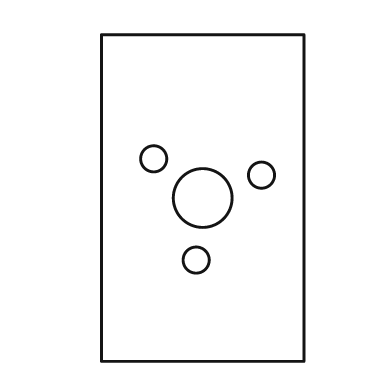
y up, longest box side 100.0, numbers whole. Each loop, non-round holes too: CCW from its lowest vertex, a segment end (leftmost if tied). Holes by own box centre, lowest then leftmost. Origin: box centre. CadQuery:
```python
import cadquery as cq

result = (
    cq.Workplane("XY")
    .moveTo(-31.0, -50.0)
    .lineTo(31.0, -50.0)
    .lineTo(31.0, 50.0)
    .lineTo(-31.0, 50.0)
    .close()
    .moveTo(-2.0, -19.0)
    .circle(4.0)
    .moveTo(0.0, 0.0)
    .circle(9.0)
    .moveTo(18.0, 7.0)
    .circle(4.0)
    .moveTo(-15.0, 12.0)
    .circle(4.0)
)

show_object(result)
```